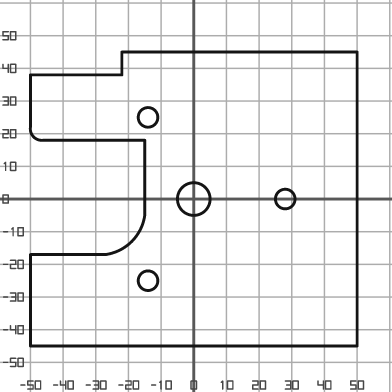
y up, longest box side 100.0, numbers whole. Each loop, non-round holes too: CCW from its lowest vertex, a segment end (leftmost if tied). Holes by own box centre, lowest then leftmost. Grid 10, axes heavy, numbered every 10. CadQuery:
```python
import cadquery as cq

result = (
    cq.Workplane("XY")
    .moveTo(-50.0, -45.0)
    .lineTo(50.0, -45.0)
    .lineTo(50.0, 45.0)
    .lineTo(-22.0, 45.0)
    .lineTo(-22.0, 38.0)
    .lineTo(-50.0, 38.0)
    .lineTo(-50.0, 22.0)
    .threePointArc((-49.0, 19.0), (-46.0, 18.0))
    .lineTo(-15.0, 18.0)
    .lineTo(-15.0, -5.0)
    .threePointArc((-19.0, -13.0), (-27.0, -17.0))
    .lineTo(-50.0, -17.0)
    .close()
    .moveTo(-14.0, -25.0)
    .circle(3.0)
    .moveTo(0.0, 0.0)
    .circle(5.0)
    .moveTo(28.0, 0.0)
    .circle(3.0)
    .moveTo(-14.0, 25.0)
    .circle(3.0)
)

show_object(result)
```